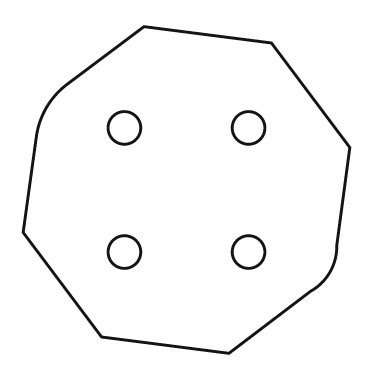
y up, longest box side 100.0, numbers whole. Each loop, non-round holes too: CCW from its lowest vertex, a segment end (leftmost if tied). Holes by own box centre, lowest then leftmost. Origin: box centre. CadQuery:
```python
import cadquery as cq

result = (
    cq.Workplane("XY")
    .moveTo(13.0, -50.0)
    .lineTo(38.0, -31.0)
    .threePointArc((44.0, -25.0), (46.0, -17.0))
    .lineTo(50.0, 13.0)
    .lineTo(26.0, 45.0)
    .lineTo(-13.0, 50.0)
    .lineTo(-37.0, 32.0)
    .threePointArc((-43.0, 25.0), (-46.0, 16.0))
    .lineTo(-50.0, -13.0)
    .lineTo(-26.0, -45.0)
    .close()
    .moveTo(-19.0, -19.0)
    .circle(5.0)
    .moveTo(19.0, -19.0)
    .circle(5.0)
    .moveTo(-19.0, 19.0)
    .circle(5.0)
    .moveTo(19.0, 19.0)
    .circle(5.0)
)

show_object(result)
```